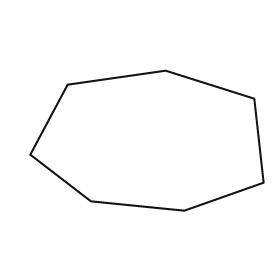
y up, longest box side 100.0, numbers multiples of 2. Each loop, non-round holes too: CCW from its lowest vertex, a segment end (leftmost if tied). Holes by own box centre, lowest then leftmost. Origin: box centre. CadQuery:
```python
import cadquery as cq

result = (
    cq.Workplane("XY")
    .moveTo(16.0, -30.0)
    .lineTo(50.0, -18.0)
    .lineTo(46.0, 18.0)
    .lineTo(8.0, 30.0)
    .lineTo(-34.0, 24.0)
    .lineTo(-50.0, -6.0)
    .lineTo(-24.0, -26.0)
    .close()
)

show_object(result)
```